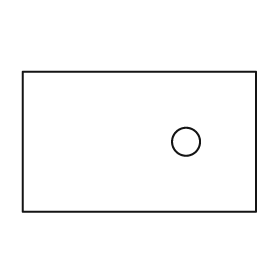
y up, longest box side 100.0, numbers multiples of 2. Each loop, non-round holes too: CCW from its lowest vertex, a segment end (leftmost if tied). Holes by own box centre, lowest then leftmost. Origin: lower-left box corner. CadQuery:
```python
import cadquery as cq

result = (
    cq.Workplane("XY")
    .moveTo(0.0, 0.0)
    .lineTo(100.0, 0.0)
    .lineTo(100.0, 60.0)
    .lineTo(0.0, 60.0)
    .close()
    .moveTo(70.0, 30.0)
    .circle(6.0)
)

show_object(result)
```